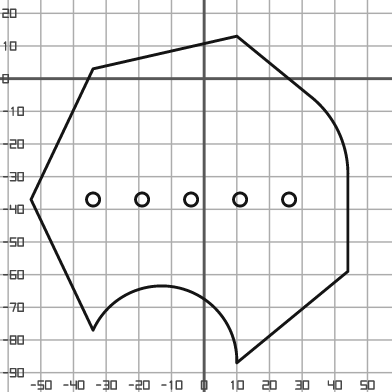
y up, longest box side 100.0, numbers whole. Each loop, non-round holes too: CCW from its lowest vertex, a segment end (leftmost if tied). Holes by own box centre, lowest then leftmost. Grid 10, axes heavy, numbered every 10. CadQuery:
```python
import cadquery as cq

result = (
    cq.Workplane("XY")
    .moveTo(10.0, -87.0)
    .lineTo(44.0, -59.0)
    .lineTo(44.0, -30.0)
    .threePointArc((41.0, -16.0), (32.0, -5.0))
    .lineTo(10.0, 13.0)
    .lineTo(-34.0, 3.0)
    .lineTo(-53.0, -37.0)
    .lineTo(-34.0, -77.0)
    .threePointArc((-8.0, -64.0), (10.0, -87.0))
    .close()
    .moveTo(-34.0, -37.0)
    .circle(2.0)
    .moveTo(-19.0, -37.0)
    .circle(2.0)
    .moveTo(-4.0, -37.0)
    .circle(2.0)
    .moveTo(11.0, -37.0)
    .circle(2.0)
    .moveTo(26.0, -37.0)
    .circle(2.0)
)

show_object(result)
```